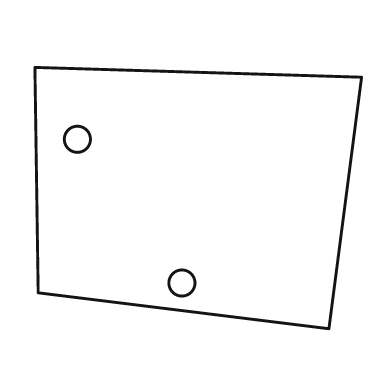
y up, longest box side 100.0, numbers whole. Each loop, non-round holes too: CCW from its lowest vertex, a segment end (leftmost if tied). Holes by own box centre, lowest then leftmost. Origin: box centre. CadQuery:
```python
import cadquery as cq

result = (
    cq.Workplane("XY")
    .moveTo(40.0, -40.0)
    .lineTo(50.0, 37.0)
    .lineTo(-50.0, 40.0)
    .lineTo(-49.0, -29.0)
    .close()
    .moveTo(-5.0, -26.0)
    .circle(4.0)
    .moveTo(-37.0, 18.0)
    .circle(4.0)
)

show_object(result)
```